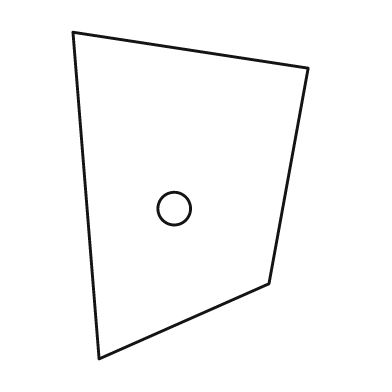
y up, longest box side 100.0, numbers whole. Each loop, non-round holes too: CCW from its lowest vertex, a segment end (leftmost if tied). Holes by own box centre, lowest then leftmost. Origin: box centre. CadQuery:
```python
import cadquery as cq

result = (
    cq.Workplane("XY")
    .moveTo(-28.0, -50.0)
    .lineTo(24.0, -27.0)
    .lineTo(36.0, 39.0)
    .lineTo(-36.0, 50.0)
    .close()
    .moveTo(-5.0, -4.0)
    .circle(5.0)
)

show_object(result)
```